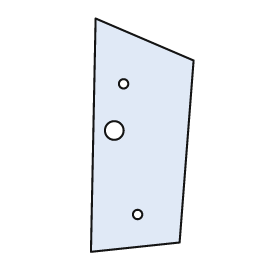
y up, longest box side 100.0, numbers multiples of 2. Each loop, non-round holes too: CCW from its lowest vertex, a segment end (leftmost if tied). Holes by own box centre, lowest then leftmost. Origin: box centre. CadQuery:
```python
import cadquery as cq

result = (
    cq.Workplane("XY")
    .moveTo(-22.0, -50.0)
    .lineTo(16.0, -46.0)
    .lineTo(22.0, 32.0)
    .lineTo(-20.0, 50.0)
    .close()
    .moveTo(-2.0, -34.0)
    .circle(2.0)
    .moveTo(-12.0, 2.0)
    .circle(4.0)
    .moveTo(-8.0, 22.0)
    .circle(2.0)
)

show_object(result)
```